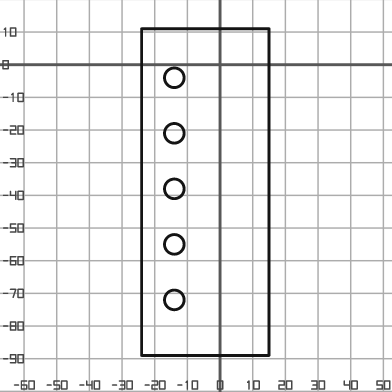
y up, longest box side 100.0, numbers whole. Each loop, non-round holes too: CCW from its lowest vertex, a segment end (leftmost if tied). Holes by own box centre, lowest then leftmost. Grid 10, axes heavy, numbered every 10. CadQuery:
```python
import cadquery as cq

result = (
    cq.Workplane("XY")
    .moveTo(-24.0, -89.0)
    .lineTo(15.0, -89.0)
    .lineTo(15.0, 11.0)
    .lineTo(-24.0, 11.0)
    .close()
    .moveTo(-14.0, -72.0)
    .circle(3.0)
    .moveTo(-14.0, -55.0)
    .circle(3.0)
    .moveTo(-14.0, -38.0)
    .circle(3.0)
    .moveTo(-14.0, -21.0)
    .circle(3.0)
    .moveTo(-14.0, -4.0)
    .circle(3.0)
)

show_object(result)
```